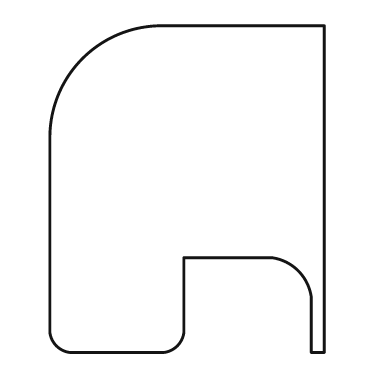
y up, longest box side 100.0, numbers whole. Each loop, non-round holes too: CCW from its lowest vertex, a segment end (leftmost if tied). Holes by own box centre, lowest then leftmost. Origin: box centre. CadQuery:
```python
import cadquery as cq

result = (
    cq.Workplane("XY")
    .moveTo(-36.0, -50.0)
    .lineTo(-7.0, -50.0)
    .threePointArc((-3.0, -48.0), (-1.0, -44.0))
    .lineTo(-1.0, -21.0)
    .lineTo(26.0, -21.0)
    .threePointArc((34.0, -25.0), (38.0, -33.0))
    .lineTo(38.0, -50.0)
    .lineTo(42.0, -50.0)
    .lineTo(42.0, 50.0)
    .lineTo(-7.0, 50.0)
    .threePointArc((-32.0, 40.0), (-42.0, 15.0))
    .lineTo(-42.0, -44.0)
    .threePointArc((-40.0, -48.0), (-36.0, -50.0))
    .close()
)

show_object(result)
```